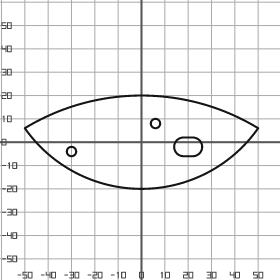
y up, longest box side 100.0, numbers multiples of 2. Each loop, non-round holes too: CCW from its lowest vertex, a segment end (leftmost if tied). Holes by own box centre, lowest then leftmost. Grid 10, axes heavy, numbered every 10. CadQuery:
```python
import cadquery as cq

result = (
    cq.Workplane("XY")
    .moveTo(-50.0, 6.0)
    .threePointArc((0.0, -20.0), (50.0, 6.0))
    .threePointArc((0.0, 20.0), (-50.0, 6.0))
    .close()
    .moveTo(-30.0, -4.0)
    .circle(2.0)
    .moveTo(18.0, -6.0)
    .lineTo(22.0, -6.0)
    .threePointArc((26.0, -2.0), (22.0, 2.0))
    .lineTo(18.0, 2.0)
    .threePointArc((14.0, -2.0), (18.0, -6.0))
    .close()
    .moveTo(6.0, 8.0)
    .circle(2.0)
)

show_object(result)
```